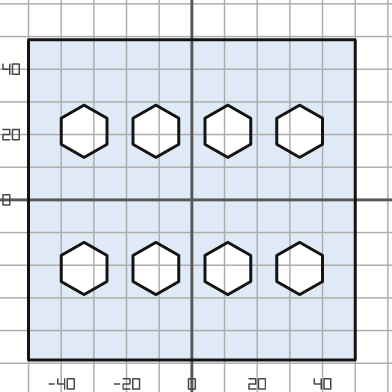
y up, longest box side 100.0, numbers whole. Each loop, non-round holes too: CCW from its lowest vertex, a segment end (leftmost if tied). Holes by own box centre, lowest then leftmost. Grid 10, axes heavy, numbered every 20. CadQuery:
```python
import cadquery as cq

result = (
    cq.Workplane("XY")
    .moveTo(-50.0, -49.0)
    .lineTo(50.0, -49.0)
    .lineTo(50.0, 49.0)
    .lineTo(-50.0, 49.0)
    .close()
    .moveTo(-33.0, -29.0)
    .lineTo(-26.0, -25.0)
    .lineTo(-26.0, -17.0)
    .lineTo(-33.0, -13.0)
    .lineTo(-40.0, -17.0)
    .lineTo(-40.0, -25.0)
    .close()
    .moveTo(-11.0, -29.0)
    .lineTo(-4.0, -25.0)
    .lineTo(-4.0, -17.0)
    .lineTo(-11.0, -13.0)
    .lineTo(-18.0, -17.0)
    .lineTo(-18.0, -25.0)
    .close()
    .moveTo(11.0, -29.0)
    .lineTo(18.0, -25.0)
    .lineTo(18.0, -17.0)
    .lineTo(11.0, -13.0)
    .lineTo(4.0, -17.0)
    .lineTo(4.0, -25.0)
    .close()
    .moveTo(33.0, -29.0)
    .lineTo(40.0, -25.0)
    .lineTo(40.0, -17.0)
    .lineTo(33.0, -13.0)
    .lineTo(26.0, -17.0)
    .lineTo(26.0, -25.0)
    .close()
    .moveTo(-33.0, 13.0)
    .lineTo(-26.0, 17.0)
    .lineTo(-26.0, 25.0)
    .lineTo(-33.0, 29.0)
    .lineTo(-40.0, 25.0)
    .lineTo(-40.0, 17.0)
    .close()
    .moveTo(-11.0, 13.0)
    .lineTo(-4.0, 17.0)
    .lineTo(-4.0, 25.0)
    .lineTo(-11.0, 29.0)
    .lineTo(-18.0, 25.0)
    .lineTo(-18.0, 17.0)
    .close()
    .moveTo(11.0, 13.0)
    .lineTo(18.0, 17.0)
    .lineTo(18.0, 25.0)
    .lineTo(11.0, 29.0)
    .lineTo(4.0, 25.0)
    .lineTo(4.0, 17.0)
    .close()
    .moveTo(33.0, 13.0)
    .lineTo(40.0, 17.0)
    .lineTo(40.0, 25.0)
    .lineTo(33.0, 29.0)
    .lineTo(26.0, 25.0)
    .lineTo(26.0, 17.0)
    .close()
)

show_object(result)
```